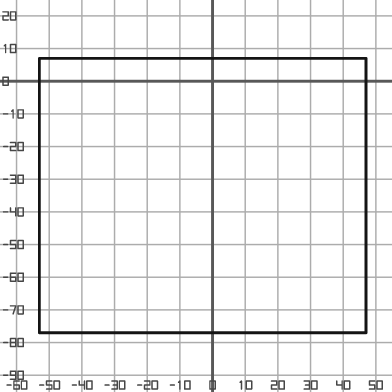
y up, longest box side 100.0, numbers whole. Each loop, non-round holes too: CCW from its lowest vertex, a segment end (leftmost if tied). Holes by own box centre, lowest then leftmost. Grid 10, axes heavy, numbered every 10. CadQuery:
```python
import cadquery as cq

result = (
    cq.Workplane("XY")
    .moveTo(-53.0, -77.0)
    .lineTo(47.0, -77.0)
    .lineTo(47.0, 7.0)
    .lineTo(-53.0, 7.0)
    .close()
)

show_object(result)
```